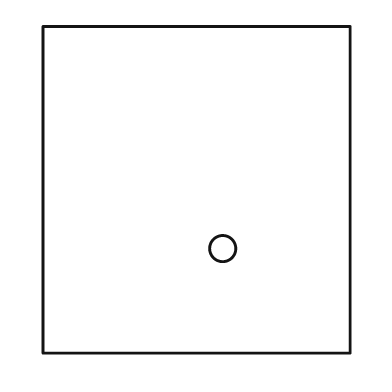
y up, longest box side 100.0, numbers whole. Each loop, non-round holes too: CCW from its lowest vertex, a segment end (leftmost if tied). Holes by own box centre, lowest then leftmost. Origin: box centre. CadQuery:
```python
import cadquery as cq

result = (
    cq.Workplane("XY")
    .moveTo(-47.0, -50.0)
    .lineTo(47.0, -50.0)
    .lineTo(47.0, 50.0)
    .lineTo(-47.0, 50.0)
    .close()
    .moveTo(8.0, -18.0)
    .circle(4.0)
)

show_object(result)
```